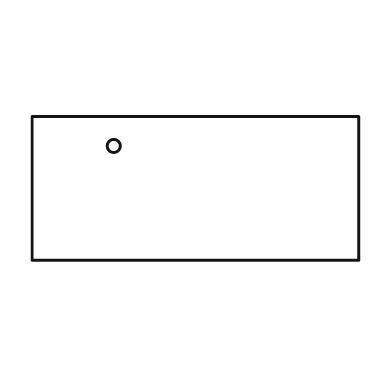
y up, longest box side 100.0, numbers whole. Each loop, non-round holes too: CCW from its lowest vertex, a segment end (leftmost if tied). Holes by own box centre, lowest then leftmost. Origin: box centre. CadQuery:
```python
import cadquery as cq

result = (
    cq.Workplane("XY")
    .moveTo(-50.0, -22.0)
    .lineTo(50.0, -22.0)
    .lineTo(50.0, 22.0)
    .lineTo(-50.0, 22.0)
    .close()
    .moveTo(-25.0, 13.0)
    .circle(2.0)
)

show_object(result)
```